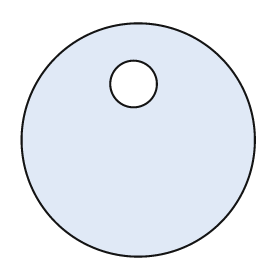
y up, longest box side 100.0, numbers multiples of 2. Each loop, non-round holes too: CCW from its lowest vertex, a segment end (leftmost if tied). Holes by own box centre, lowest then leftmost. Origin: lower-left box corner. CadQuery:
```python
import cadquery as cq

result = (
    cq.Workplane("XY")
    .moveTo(50.0, 50.0)
    .circle(50.0)
    .moveTo(48.0, 74.0)
    .circle(10.0)
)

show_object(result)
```